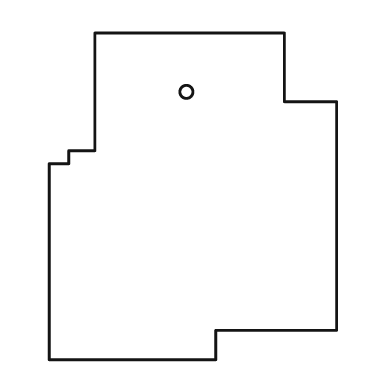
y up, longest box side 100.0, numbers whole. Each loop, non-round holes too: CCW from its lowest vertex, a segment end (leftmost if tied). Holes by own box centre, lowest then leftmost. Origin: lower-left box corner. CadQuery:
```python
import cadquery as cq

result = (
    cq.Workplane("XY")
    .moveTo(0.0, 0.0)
    .lineTo(51.0, 0.0)
    .lineTo(51.0, 9.0)
    .lineTo(88.0, 9.0)
    .lineTo(88.0, 79.0)
    .lineTo(72.0, 79.0)
    .lineTo(72.0, 100.0)
    .lineTo(14.0, 100.0)
    .lineTo(14.0, 64.0)
    .lineTo(6.0, 64.0)
    .lineTo(6.0, 60.0)
    .lineTo(0.0, 60.0)
    .close()
    .moveTo(42.0, 82.0)
    .circle(2.0)
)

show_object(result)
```